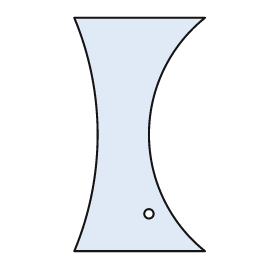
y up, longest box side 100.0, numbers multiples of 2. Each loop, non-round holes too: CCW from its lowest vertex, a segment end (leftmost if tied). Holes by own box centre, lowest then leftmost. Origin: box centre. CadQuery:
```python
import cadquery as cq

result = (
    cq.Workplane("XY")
    .moveTo(-28.0, -50.0)
    .lineTo(28.0, -50.0)
    .threePointArc((4.0, 0.0), (28.0, 50.0))
    .lineTo(-28.0, 50.0)
    .threePointArc((-18.0, 0.0), (-28.0, -50.0))
    .close()
    .moveTo(4.0, -34.0)
    .circle(2.0)
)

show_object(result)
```